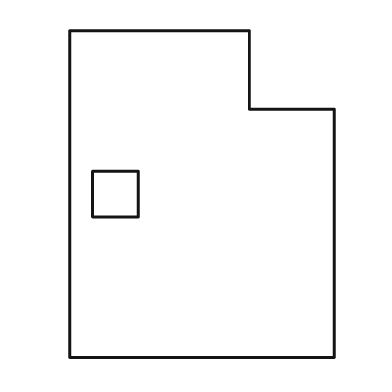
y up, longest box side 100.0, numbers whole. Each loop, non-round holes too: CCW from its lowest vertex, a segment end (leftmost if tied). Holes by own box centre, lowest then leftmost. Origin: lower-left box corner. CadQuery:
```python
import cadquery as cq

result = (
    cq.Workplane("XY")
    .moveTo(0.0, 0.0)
    .lineTo(81.0, 0.0)
    .lineTo(81.0, 76.0)
    .lineTo(55.0, 76.0)
    .lineTo(55.0, 100.0)
    .lineTo(0.0, 100.0)
    .close()
    .moveTo(7.0, 43.0)
    .lineTo(21.0, 43.0)
    .lineTo(21.0, 57.0)
    .lineTo(7.0, 57.0)
    .close()
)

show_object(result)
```